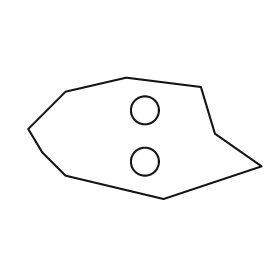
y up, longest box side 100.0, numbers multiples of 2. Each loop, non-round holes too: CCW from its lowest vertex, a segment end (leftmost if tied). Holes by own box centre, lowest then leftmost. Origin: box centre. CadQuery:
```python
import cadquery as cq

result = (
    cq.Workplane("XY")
    .moveTo(8.0, -26.0)
    .lineTo(50.0, -12.0)
    .lineTo(30.0, 2.0)
    .lineTo(24.0, 22.0)
    .lineTo(-8.0, 26.0)
    .lineTo(-34.0, 20.0)
    .lineTo(-50.0, 4.0)
    .lineTo(-44.0, -6.0)
    .lineTo(-34.0, -16.0)
    .close()
    .moveTo(0.0, -10.0)
    .circle(6.0)
    .moveTo(0.0, 12.0)
    .circle(6.0)
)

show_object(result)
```